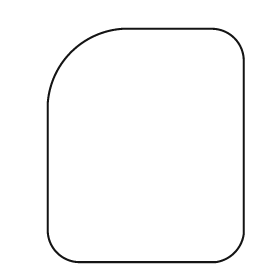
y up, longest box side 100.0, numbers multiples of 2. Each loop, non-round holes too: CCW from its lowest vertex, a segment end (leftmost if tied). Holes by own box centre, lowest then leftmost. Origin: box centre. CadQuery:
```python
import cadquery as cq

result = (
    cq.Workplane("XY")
    .moveTo(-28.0, -50.0)
    .lineTo(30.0, -50.0)
    .threePointArc((38.0, -46.0), (42.0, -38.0))
    .lineTo(42.0, 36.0)
    .threePointArc((38.0, 46.0), (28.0, 50.0))
    .lineTo(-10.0, 50.0)
    .threePointArc((-32.0, 40.0), (-42.0, 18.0))
    .lineTo(-42.0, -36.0)
    .threePointArc((-38.0, -46.0), (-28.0, -50.0))
    .close()
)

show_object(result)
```